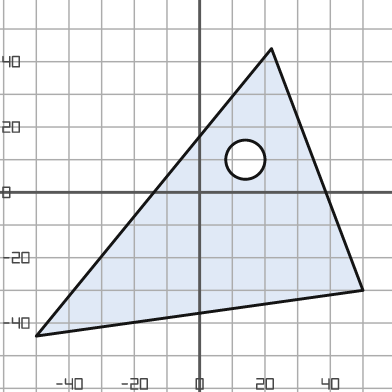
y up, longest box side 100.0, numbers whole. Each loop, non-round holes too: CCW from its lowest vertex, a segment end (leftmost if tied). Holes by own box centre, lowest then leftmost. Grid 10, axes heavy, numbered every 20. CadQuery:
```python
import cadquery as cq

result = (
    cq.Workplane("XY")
    .moveTo(-50.0, -44.0)
    .lineTo(50.0, -30.0)
    .lineTo(22.0, 44.0)
    .close()
    .moveTo(14.0, 10.0)
    .circle(6.0)
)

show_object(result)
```